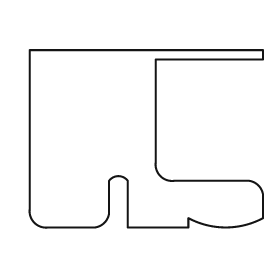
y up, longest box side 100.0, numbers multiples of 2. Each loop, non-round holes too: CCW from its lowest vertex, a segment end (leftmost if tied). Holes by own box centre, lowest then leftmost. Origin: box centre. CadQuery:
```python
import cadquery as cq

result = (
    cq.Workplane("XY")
    .moveTo(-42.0, -38.0)
    .lineTo(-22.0, -38.0)
    .threePointArc((-18.0, -36.0), (-16.0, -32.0))
    .lineTo(-16.0, -18.0)
    .threePointArc((-12.0, -16.0), (-8.0, -18.0))
    .lineTo(-8.0, -38.0)
    .lineTo(18.0, -38.0)
    .lineTo(18.0, -34.0)
    .threePointArc((34.0, -38.0), (50.0, -34.0))
    .lineTo(50.0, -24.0)
    .threePointArc((48.0, -20.0), (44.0, -18.0))
    .lineTo(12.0, -18.0)
    .threePointArc((6.0, -16.0), (4.0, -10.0))
    .lineTo(4.0, 34.0)
    .lineTo(50.0, 34.0)
    .lineTo(50.0, 38.0)
    .lineTo(-50.0, 38.0)
    .lineTo(-50.0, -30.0)
    .threePointArc((-48.0, -36.0), (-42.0, -38.0))
    .close()
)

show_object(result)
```